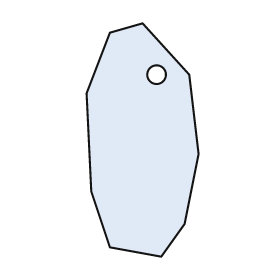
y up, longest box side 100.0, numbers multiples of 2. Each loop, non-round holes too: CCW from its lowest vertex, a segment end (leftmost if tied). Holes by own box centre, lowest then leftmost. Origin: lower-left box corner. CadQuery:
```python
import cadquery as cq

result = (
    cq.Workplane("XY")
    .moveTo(32.0, 0.0)
    .lineTo(42.0, 14.0)
    .lineTo(48.0, 44.0)
    .lineTo(44.0, 78.0)
    .lineTo(24.0, 100.0)
    .lineTo(10.0, 96.0)
    .lineTo(0.0, 70.0)
    .lineTo(2.0, 28.0)
    .lineTo(10.0, 4.0)
    .close()
    .moveTo(30.0, 78.0)
    .circle(4.0)
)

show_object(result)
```